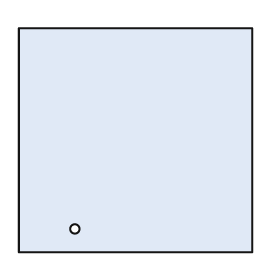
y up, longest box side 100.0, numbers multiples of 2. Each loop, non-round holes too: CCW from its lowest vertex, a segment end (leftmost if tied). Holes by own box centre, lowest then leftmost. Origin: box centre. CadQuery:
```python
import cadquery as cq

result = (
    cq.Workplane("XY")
    .moveTo(-50.0, -48.0)
    .lineTo(50.0, -48.0)
    .lineTo(50.0, 48.0)
    .lineTo(-50.0, 48.0)
    .close()
    .moveTo(-26.0, -38.0)
    .circle(2.0)
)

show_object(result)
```